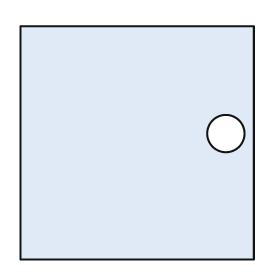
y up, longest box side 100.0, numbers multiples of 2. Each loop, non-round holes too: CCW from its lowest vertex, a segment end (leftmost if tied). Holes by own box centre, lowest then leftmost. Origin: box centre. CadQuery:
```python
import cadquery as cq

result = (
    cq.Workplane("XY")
    .moveTo(-50.0, -50.0)
    .lineTo(50.0, -50.0)
    .lineTo(50.0, 50.0)
    .lineTo(-50.0, 50.0)
    .close()
    .moveTo(38.0, 4.0)
    .circle(8.0)
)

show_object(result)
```